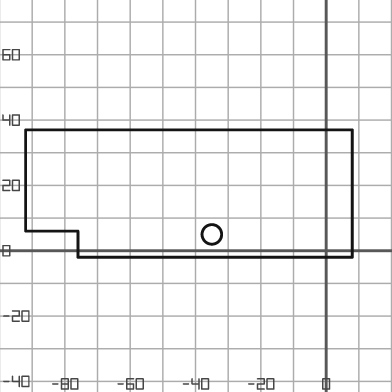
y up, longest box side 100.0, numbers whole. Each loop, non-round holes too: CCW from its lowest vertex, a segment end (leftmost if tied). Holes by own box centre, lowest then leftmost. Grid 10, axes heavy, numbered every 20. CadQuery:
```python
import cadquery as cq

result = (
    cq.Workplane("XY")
    .moveTo(-76.0, -2.0)
    .lineTo(8.0, -2.0)
    .lineTo(8.0, 37.0)
    .lineTo(-92.0, 37.0)
    .lineTo(-92.0, 6.0)
    .lineTo(-76.0, 6.0)
    .close()
    .moveTo(-35.0, 5.0)
    .circle(3.0)
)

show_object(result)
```